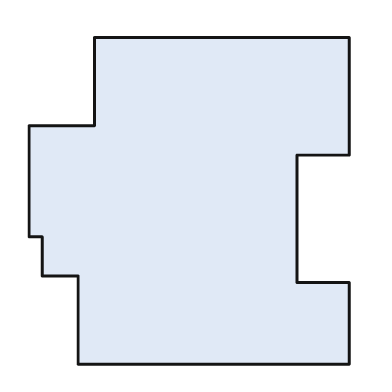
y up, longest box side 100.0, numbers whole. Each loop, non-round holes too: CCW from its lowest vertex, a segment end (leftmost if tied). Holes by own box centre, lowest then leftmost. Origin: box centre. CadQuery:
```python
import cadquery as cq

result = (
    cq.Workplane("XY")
    .moveTo(-34.0, -50.0)
    .lineTo(49.0, -50.0)
    .lineTo(49.0, -25.0)
    .lineTo(33.0, -25.0)
    .lineTo(33.0, 14.0)
    .lineTo(49.0, 14.0)
    .lineTo(49.0, 50.0)
    .lineTo(-29.0, 50.0)
    .lineTo(-29.0, 23.0)
    .lineTo(-49.0, 23.0)
    .lineTo(-49.0, -11.0)
    .lineTo(-45.0, -11.0)
    .lineTo(-45.0, -23.0)
    .lineTo(-34.0, -23.0)
    .close()
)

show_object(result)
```